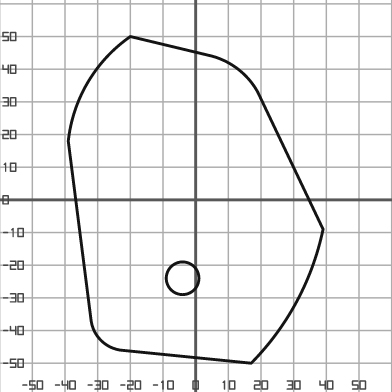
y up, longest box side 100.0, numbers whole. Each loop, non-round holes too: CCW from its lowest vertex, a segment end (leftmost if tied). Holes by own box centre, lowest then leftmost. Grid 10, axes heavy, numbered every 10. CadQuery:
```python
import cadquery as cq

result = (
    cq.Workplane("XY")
    .moveTo(17.0, -50.0)
    .threePointArc((31.0, -31.0), (39.0, -9.0))
    .lineTo(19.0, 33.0)
    .threePointArc((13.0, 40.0), (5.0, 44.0))
    .lineTo(-20.0, 50.0)
    .threePointArc((-33.0, 36.0), (-39.0, 18.0))
    .lineTo(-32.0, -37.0)
    .threePointArc((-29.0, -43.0), (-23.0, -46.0))
    .close()
    .moveTo(-4.0, -24.0)
    .circle(5.0)
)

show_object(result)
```